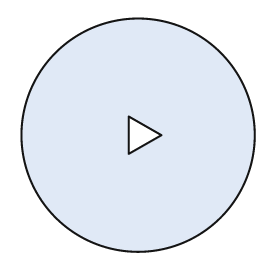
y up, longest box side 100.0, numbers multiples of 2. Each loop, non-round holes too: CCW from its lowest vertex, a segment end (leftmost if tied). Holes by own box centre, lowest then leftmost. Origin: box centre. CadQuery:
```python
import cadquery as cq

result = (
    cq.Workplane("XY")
    .moveTo(0.0, 0.0)
    .circle(50.0)
    .moveTo(-4.0, -8.0)
    .lineTo(10.0, 0.0)
    .lineTo(-4.0, 8.0)
    .close()
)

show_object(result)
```